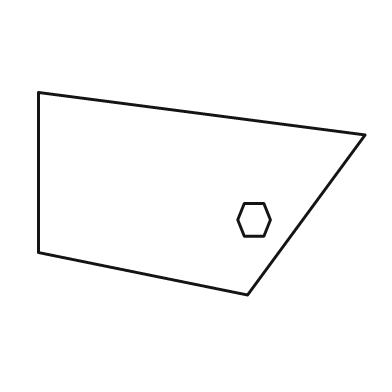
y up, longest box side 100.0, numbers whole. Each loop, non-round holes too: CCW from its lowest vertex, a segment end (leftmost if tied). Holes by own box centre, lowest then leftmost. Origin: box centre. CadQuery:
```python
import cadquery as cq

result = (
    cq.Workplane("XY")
    .moveTo(14.0, -31.0)
    .lineTo(50.0, 18.0)
    .lineTo(-50.0, 31.0)
    .lineTo(-50.0, -18.0)
    .close()
    .moveTo(13.0, -13.0)
    .lineTo(19.0, -13.0)
    .lineTo(21.0, -8.0)
    .lineTo(19.0, -3.0)
    .lineTo(13.0, -3.0)
    .lineTo(11.0, -8.0)
    .close()
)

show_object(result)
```